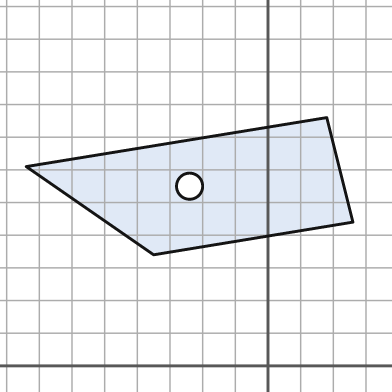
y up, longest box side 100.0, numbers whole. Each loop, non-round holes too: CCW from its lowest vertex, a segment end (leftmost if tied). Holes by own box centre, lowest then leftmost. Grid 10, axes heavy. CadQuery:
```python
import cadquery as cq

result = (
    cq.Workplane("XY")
    .moveTo(-35.0, 34.0)
    .lineTo(26.0, 44.0)
    .lineTo(18.0, 76.0)
    .lineTo(-74.0, 61.0)
    .close()
    .moveTo(-24.0, 55.0)
    .circle(4.0)
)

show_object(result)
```